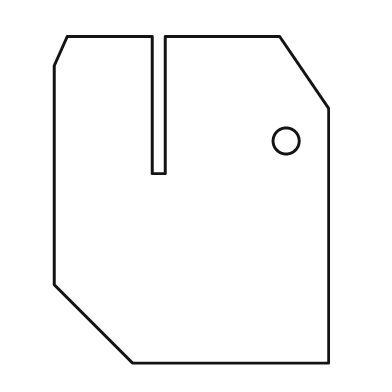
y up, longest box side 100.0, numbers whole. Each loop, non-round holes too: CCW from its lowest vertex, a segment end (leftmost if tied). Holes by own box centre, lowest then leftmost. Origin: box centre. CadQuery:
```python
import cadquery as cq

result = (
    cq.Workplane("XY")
    .moveTo(-18.0, -50.0)
    .lineTo(42.0, -50.0)
    .lineTo(42.0, 28.0)
    .lineTo(27.0, 50.0)
    .lineTo(-8.0, 50.0)
    .lineTo(-8.0, 8.0)
    .lineTo(-12.0, 8.0)
    .lineTo(-12.0, 50.0)
    .lineTo(-38.0, 50.0)
    .lineTo(-42.0, 41.0)
    .lineTo(-42.0, -26.0)
    .close()
    .moveTo(29.0, 18.0)
    .circle(4.0)
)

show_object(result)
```